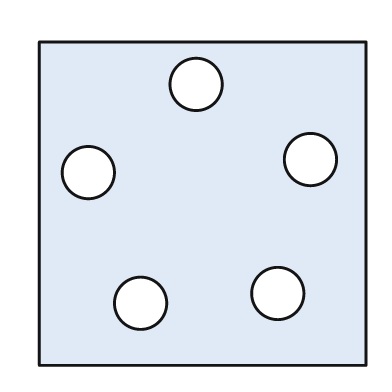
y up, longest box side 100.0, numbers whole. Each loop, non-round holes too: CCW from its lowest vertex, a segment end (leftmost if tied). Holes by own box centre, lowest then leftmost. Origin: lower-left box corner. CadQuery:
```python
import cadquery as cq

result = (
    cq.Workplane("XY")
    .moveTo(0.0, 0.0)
    .lineTo(100.0, 0.0)
    .lineTo(100.0, 99.0)
    .lineTo(0.0, 99.0)
    .close()
    .moveTo(31.0, 19.0)
    .circle(8.0)
    .moveTo(73.0, 22.0)
    .circle(8.0)
    .moveTo(15.0, 59.0)
    .circle(8.0)
    .moveTo(83.0, 63.0)
    .circle(8.0)
    .moveTo(48.0, 86.0)
    .circle(8.0)
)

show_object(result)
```